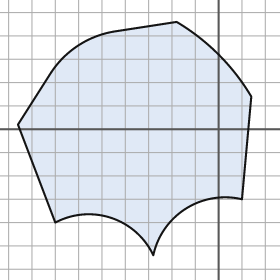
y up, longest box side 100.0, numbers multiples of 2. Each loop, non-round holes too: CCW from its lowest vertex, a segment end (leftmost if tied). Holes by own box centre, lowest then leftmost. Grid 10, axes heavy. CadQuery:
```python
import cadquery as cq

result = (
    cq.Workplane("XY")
    .moveTo(-28.0, -54.0)
    .threePointArc((-14.0, -34.0), (10.0, -30.0))
    .lineTo(14.0, 14.0)
    .threePointArc((0.0, 32.0), (-18.0, 46.0))
    .lineTo(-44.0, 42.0)
    .threePointArc((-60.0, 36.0), (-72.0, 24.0))
    .lineTo(-86.0, 2.0)
    .lineTo(-70.0, -40.0)
    .threePointArc((-46.0, -38.0), (-28.0, -54.0))
    .close()
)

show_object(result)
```